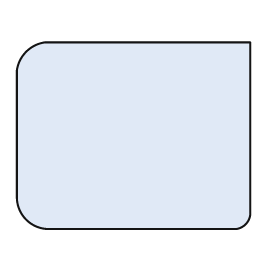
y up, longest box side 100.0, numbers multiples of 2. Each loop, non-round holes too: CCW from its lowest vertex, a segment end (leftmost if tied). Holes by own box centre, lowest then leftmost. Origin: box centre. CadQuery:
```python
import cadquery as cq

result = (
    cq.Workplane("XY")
    .moveTo(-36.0, -40.0)
    .lineTo(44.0, -40.0)
    .threePointArc((48.0, -38.0), (50.0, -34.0))
    .lineTo(50.0, 40.0)
    .lineTo(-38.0, 40.0)
    .threePointArc((-46.0, 36.0), (-50.0, 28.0))
    .lineTo(-50.0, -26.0)
    .threePointArc((-46.0, -36.0), (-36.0, -40.0))
    .close()
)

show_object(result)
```